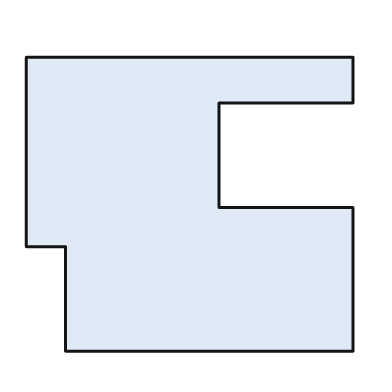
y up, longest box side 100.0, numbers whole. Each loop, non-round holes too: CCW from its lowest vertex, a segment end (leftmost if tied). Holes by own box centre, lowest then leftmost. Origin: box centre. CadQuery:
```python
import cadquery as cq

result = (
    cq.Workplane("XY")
    .moveTo(-38.0, -45.0)
    .lineTo(50.0, -45.0)
    .lineTo(50.0, -1.0)
    .lineTo(9.0, -1.0)
    .lineTo(9.0, 31.0)
    .lineTo(50.0, 31.0)
    .lineTo(50.0, 45.0)
    .lineTo(-50.0, 45.0)
    .lineTo(-50.0, -13.0)
    .lineTo(-38.0, -13.0)
    .close()
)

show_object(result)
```